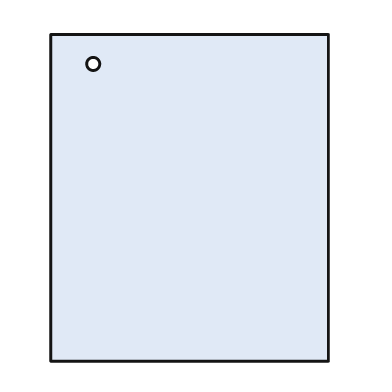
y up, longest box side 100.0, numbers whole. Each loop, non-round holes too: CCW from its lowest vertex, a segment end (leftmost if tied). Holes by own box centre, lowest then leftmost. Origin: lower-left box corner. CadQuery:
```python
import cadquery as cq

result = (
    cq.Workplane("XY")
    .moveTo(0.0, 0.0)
    .lineTo(85.0, 0.0)
    .lineTo(85.0, 100.0)
    .lineTo(0.0, 100.0)
    .close()
    .moveTo(13.0, 91.0)
    .circle(2.0)
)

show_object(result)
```